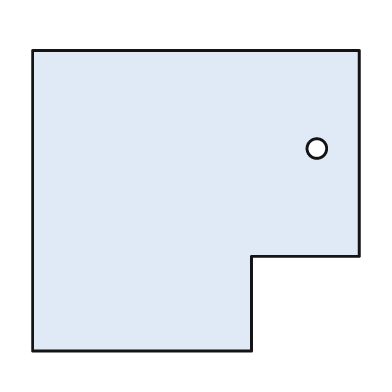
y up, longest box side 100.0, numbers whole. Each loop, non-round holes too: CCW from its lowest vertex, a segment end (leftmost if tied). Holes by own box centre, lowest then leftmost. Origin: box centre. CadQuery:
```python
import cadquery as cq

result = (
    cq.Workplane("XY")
    .moveTo(-50.0, -46.0)
    .lineTo(17.0, -46.0)
    .lineTo(17.0, -17.0)
    .lineTo(50.0, -17.0)
    .lineTo(50.0, 46.0)
    .lineTo(-50.0, 46.0)
    .close()
    .moveTo(37.0, 16.0)
    .circle(3.0)
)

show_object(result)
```